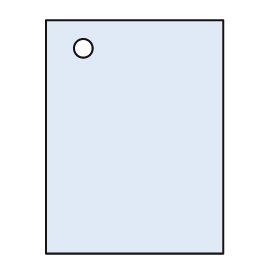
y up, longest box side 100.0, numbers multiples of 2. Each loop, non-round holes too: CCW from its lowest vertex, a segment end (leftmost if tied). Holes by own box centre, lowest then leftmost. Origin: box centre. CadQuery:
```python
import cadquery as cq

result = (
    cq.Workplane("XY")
    .moveTo(-38.0, -50.0)
    .lineTo(38.0, -50.0)
    .lineTo(38.0, 50.0)
    .lineTo(-38.0, 50.0)
    .close()
    .moveTo(-22.0, 38.0)
    .circle(4.0)
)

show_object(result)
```